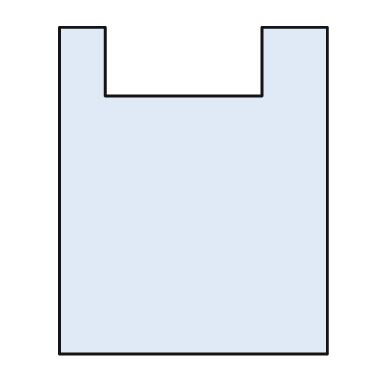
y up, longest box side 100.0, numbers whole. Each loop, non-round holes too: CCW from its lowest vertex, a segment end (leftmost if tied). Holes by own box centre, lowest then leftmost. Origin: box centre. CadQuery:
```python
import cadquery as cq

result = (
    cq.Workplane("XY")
    .moveTo(-41.0, -50.0)
    .lineTo(41.0, -50.0)
    .lineTo(41.0, 50.0)
    .lineTo(21.0, 50.0)
    .lineTo(21.0, 29.0)
    .lineTo(-27.0, 29.0)
    .lineTo(-27.0, 50.0)
    .lineTo(-41.0, 50.0)
    .close()
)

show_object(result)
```